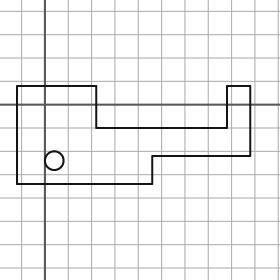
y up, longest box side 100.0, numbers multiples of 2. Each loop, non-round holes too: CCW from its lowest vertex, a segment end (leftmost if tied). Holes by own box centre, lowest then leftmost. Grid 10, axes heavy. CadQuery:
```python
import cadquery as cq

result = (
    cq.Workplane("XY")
    .moveTo(-12.0, -34.0)
    .lineTo(46.0, -34.0)
    .lineTo(46.0, -22.0)
    .lineTo(88.0, -22.0)
    .lineTo(88.0, 8.0)
    .lineTo(78.0, 8.0)
    .lineTo(78.0, -10.0)
    .lineTo(22.0, -10.0)
    .lineTo(22.0, 8.0)
    .lineTo(-12.0, 8.0)
    .close()
    .moveTo(4.0, -24.0)
    .circle(4.0)
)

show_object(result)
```